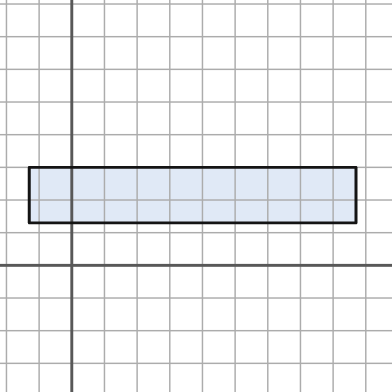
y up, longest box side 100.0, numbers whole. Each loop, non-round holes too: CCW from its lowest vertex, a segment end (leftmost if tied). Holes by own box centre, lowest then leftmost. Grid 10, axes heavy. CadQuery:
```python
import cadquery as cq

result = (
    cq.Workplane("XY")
    .moveTo(-13.0, 13.0)
    .lineTo(87.0, 13.0)
    .lineTo(87.0, 30.0)
    .lineTo(-13.0, 30.0)
    .close()
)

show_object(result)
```